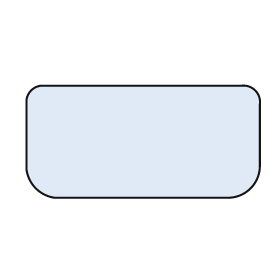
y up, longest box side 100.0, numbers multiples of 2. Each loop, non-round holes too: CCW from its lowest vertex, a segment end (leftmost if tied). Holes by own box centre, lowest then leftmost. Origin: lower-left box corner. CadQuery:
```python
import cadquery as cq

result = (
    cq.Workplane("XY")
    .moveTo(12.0, 0.0)
    .lineTo(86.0, 0.0)
    .threePointArc((96.0, 4.0), (100.0, 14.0))
    .lineTo(100.0, 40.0)
    .threePointArc((98.0, 46.0), (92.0, 48.0))
    .lineTo(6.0, 48.0)
    .threePointArc((2.0, 46.0), (0.0, 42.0))
    .lineTo(0.0, 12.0)
    .threePointArc((4.0, 4.0), (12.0, 0.0))
    .close()
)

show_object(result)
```